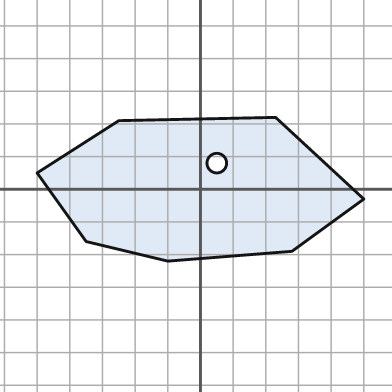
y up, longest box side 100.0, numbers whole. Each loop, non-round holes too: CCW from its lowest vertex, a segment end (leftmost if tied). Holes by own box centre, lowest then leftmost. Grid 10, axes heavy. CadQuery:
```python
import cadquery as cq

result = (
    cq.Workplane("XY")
    .moveTo(-10.0, -22.0)
    .lineTo(28.0, -19.0)
    .lineTo(50.0, -3.0)
    .lineTo(23.0, 22.0)
    .lineTo(-25.0, 21.0)
    .lineTo(-50.0, 5.0)
    .lineTo(-35.0, -16.0)
    .close()
    .moveTo(5.0, 8.0)
    .circle(3.0)
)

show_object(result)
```